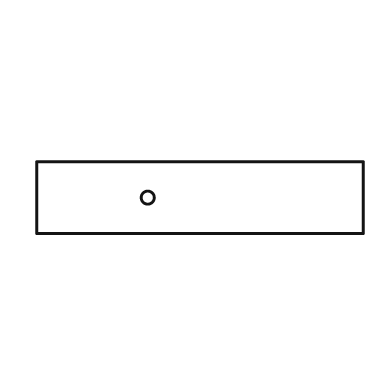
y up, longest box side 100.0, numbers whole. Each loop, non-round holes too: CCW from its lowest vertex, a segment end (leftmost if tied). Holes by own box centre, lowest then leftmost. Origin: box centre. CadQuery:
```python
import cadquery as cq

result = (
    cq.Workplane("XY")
    .moveTo(-50.0, -11.0)
    .lineTo(50.0, -11.0)
    .lineTo(50.0, 11.0)
    .lineTo(-50.0, 11.0)
    .close()
    .moveTo(-16.0, 0.0)
    .circle(2.0)
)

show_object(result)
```